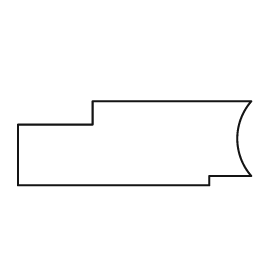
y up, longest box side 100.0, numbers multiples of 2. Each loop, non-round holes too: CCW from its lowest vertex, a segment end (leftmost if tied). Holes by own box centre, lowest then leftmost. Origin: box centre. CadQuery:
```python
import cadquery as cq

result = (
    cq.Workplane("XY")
    .moveTo(-50.0, -18.0)
    .lineTo(32.0, -18.0)
    .lineTo(32.0, -14.0)
    .lineTo(50.0, -14.0)
    .threePointArc((44.0, 2.0), (50.0, 18.0))
    .lineTo(-18.0, 18.0)
    .lineTo(-18.0, 8.0)
    .lineTo(-50.0, 8.0)
    .close()
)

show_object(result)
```